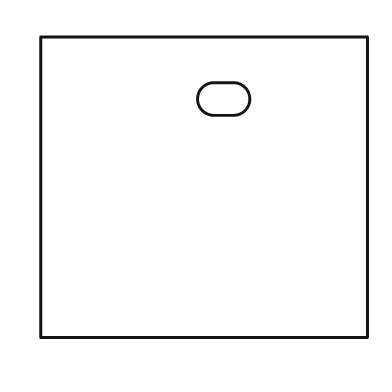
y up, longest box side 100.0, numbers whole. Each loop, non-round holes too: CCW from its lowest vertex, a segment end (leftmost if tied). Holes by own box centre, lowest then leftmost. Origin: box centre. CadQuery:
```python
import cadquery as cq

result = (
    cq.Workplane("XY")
    .moveTo(-50.0, -46.0)
    .lineTo(50.0, -46.0)
    .lineTo(50.0, 46.0)
    .lineTo(-50.0, 46.0)
    .close()
    .moveTo(3.0, 22.0)
    .lineTo(9.0, 22.0)
    .threePointArc((14.0, 27.0), (9.0, 32.0))
    .lineTo(3.0, 32.0)
    .threePointArc((-2.0, 27.0), (3.0, 22.0))
    .close()
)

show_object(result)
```